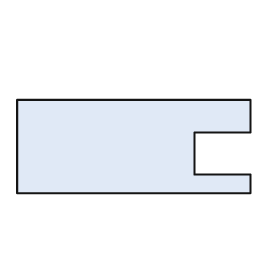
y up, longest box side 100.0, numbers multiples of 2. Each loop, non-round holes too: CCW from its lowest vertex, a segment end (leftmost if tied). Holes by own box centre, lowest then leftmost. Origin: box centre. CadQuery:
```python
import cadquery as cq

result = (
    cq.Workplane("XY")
    .moveTo(-50.0, -20.0)
    .lineTo(50.0, -20.0)
    .lineTo(50.0, -12.0)
    .lineTo(26.0, -12.0)
    .lineTo(26.0, 6.0)
    .lineTo(50.0, 6.0)
    .lineTo(50.0, 20.0)
    .lineTo(-50.0, 20.0)
    .close()
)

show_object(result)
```